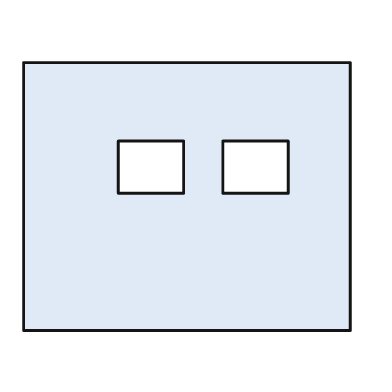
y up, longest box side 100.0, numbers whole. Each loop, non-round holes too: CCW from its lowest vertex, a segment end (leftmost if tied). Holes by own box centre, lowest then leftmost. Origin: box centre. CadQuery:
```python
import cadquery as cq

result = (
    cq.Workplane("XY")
    .moveTo(-50.0, -41.0)
    .lineTo(50.0, -41.0)
    .lineTo(50.0, 41.0)
    .lineTo(-50.0, 41.0)
    .close()
    .moveTo(-21.0, 1.0)
    .lineTo(-1.0, 1.0)
    .lineTo(-1.0, 17.0)
    .lineTo(-21.0, 17.0)
    .close()
    .moveTo(11.0, 1.0)
    .lineTo(31.0, 1.0)
    .lineTo(31.0, 17.0)
    .lineTo(11.0, 17.0)
    .close()
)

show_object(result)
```